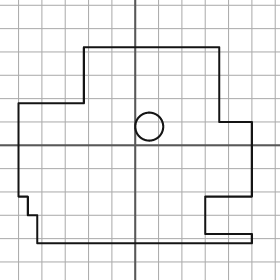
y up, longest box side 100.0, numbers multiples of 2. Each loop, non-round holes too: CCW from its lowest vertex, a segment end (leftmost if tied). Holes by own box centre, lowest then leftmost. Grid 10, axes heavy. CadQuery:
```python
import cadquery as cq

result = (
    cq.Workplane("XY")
    .moveTo(-42.0, -42.0)
    .lineTo(50.0, -42.0)
    .lineTo(50.0, -38.0)
    .lineTo(30.0, -38.0)
    .lineTo(30.0, -22.0)
    .lineTo(50.0, -22.0)
    .lineTo(50.0, 10.0)
    .lineTo(36.0, 10.0)
    .lineTo(36.0, 42.0)
    .lineTo(-22.0, 42.0)
    .lineTo(-22.0, 18.0)
    .lineTo(-50.0, 18.0)
    .lineTo(-50.0, -22.0)
    .lineTo(-46.0, -22.0)
    .lineTo(-46.0, -30.0)
    .lineTo(-42.0, -30.0)
    .close()
    .moveTo(6.0, 8.0)
    .circle(6.0)
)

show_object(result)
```